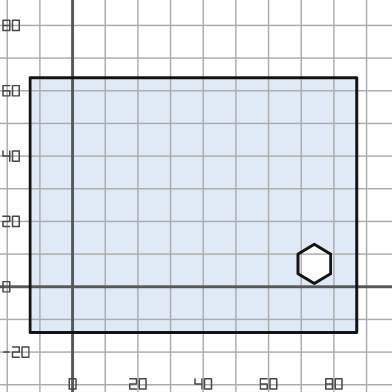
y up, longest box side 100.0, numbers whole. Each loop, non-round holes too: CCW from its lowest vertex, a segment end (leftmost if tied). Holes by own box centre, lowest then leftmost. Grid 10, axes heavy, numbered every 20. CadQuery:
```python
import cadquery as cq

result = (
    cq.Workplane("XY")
    .moveTo(-13.0, -14.0)
    .lineTo(87.0, -14.0)
    .lineTo(87.0, 64.0)
    .lineTo(-13.0, 64.0)
    .close()
    .moveTo(74.0, 1.0)
    .lineTo(79.0, 4.0)
    .lineTo(79.0, 10.0)
    .lineTo(74.0, 13.0)
    .lineTo(69.0, 10.0)
    .lineTo(69.0, 4.0)
    .close()
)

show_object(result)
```